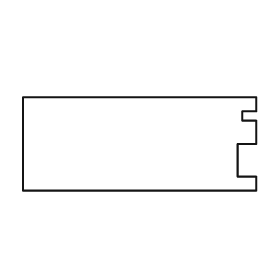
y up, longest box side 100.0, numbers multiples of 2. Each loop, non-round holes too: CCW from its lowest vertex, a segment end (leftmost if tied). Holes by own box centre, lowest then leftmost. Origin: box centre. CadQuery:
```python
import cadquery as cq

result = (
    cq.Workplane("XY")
    .moveTo(-50.0, -20.0)
    .lineTo(50.0, -20.0)
    .lineTo(50.0, -14.0)
    .lineTo(42.0, -14.0)
    .lineTo(42.0, 0.0)
    .lineTo(50.0, 0.0)
    .lineTo(50.0, 10.0)
    .lineTo(44.0, 10.0)
    .lineTo(44.0, 14.0)
    .lineTo(50.0, 14.0)
    .lineTo(50.0, 20.0)
    .lineTo(-50.0, 20.0)
    .close()
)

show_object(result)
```